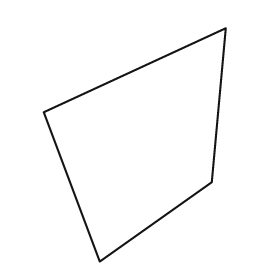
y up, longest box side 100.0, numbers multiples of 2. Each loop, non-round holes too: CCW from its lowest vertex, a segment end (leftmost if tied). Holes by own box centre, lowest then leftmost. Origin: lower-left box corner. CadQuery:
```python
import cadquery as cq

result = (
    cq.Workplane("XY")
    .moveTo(24.0, 0.0)
    .lineTo(72.0, 34.0)
    .lineTo(78.0, 100.0)
    .lineTo(0.0, 64.0)
    .close()
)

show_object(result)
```